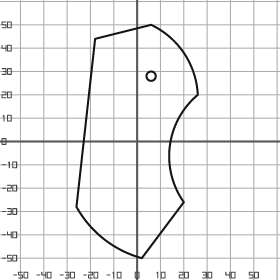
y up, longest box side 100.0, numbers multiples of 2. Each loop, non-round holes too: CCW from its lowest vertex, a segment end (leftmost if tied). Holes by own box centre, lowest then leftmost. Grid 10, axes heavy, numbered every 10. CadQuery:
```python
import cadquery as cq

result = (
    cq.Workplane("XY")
    .moveTo(2.0, -50.0)
    .lineTo(20.0, -26.0)
    .threePointArc((14.0, -2.0), (26.0, 20.0))
    .threePointArc((20.0, 38.0), (6.0, 50.0))
    .lineTo(-18.0, 44.0)
    .lineTo(-26.0, -28.0)
    .threePointArc((-14.0, -42.0), (2.0, -50.0))
    .close()
    .moveTo(6.0, 28.0)
    .circle(2.0)
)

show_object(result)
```